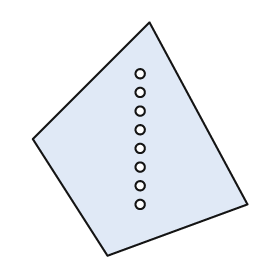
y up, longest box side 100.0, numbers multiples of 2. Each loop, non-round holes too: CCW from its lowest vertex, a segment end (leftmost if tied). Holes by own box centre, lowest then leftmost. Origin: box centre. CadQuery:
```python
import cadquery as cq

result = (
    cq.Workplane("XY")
    .moveTo(-14.0, -50.0)
    .lineTo(46.0, -28.0)
    .lineTo(4.0, 50.0)
    .lineTo(-46.0, 0.0)
    .close()
    .moveTo(0.0, -28.0)
    .circle(2.0)
    .moveTo(0.0, -20.0)
    .circle(2.0)
    .moveTo(0.0, -12.0)
    .circle(2.0)
    .moveTo(0.0, -4.0)
    .circle(2.0)
    .moveTo(0.0, 4.0)
    .circle(2.0)
    .moveTo(0.0, 12.0)
    .circle(2.0)
    .moveTo(0.0, 20.0)
    .circle(2.0)
    .moveTo(0.0, 28.0)
    .circle(2.0)
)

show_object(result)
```